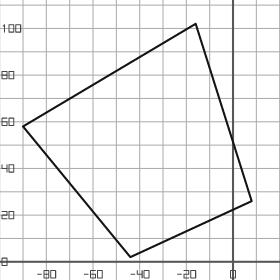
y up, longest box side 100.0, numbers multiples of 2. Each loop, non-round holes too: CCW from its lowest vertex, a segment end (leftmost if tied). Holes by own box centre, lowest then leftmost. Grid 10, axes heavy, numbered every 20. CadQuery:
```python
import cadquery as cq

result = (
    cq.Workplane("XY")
    .moveTo(-44.0, 2.0)
    .lineTo(8.0, 26.0)
    .lineTo(-16.0, 102.0)
    .lineTo(-90.0, 58.0)
    .close()
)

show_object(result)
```